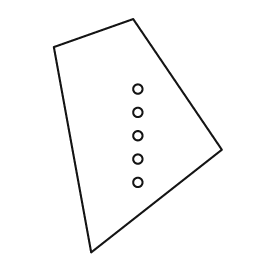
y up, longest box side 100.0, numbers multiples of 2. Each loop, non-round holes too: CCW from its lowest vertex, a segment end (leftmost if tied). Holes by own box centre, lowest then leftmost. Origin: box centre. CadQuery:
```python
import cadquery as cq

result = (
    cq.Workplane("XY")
    .moveTo(-20.0, -50.0)
    .lineTo(36.0, -6.0)
    .lineTo(-2.0, 50.0)
    .lineTo(-36.0, 38.0)
    .close()
    .moveTo(0.0, -20.0)
    .circle(2.0)
    .moveTo(0.0, -10.0)
    .circle(2.0)
    .moveTo(0.0, 0.0)
    .circle(2.0)
    .moveTo(0.0, 10.0)
    .circle(2.0)
    .moveTo(0.0, 20.0)
    .circle(2.0)
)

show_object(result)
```